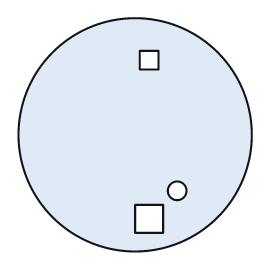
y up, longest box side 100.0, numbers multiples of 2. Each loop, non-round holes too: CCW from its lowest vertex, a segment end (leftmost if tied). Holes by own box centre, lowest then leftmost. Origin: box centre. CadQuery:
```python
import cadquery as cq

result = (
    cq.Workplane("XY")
    .moveTo(0.0, 0.0)
    .circle(50.0)
    .moveTo(0.0, -42.0)
    .lineTo(12.0, -42.0)
    .lineTo(12.0, -30.0)
    .lineTo(0.0, -30.0)
    .close()
    .moveTo(18.0, -24.0)
    .circle(4.0)
    .moveTo(2.0, 28.0)
    .lineTo(10.0, 28.0)
    .lineTo(10.0, 36.0)
    .lineTo(2.0, 36.0)
    .close()
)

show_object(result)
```